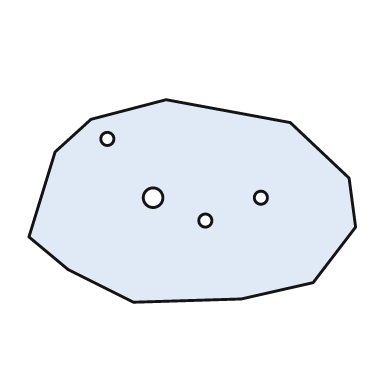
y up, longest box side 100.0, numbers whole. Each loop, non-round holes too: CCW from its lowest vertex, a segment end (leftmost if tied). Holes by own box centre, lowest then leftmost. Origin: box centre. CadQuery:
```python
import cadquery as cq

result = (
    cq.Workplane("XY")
    .moveTo(-18.0, -31.0)
    .lineTo(15.0, -30.0)
    .lineTo(37.0, -25.0)
    .lineTo(50.0, -8.0)
    .lineTo(48.0, 7.0)
    .lineTo(30.0, 24.0)
    .lineTo(-8.0, 31.0)
    .lineTo(-31.0, 25.0)
    .lineTo(-42.0, 15.0)
    .lineTo(-50.0, -11.0)
    .lineTo(-38.0, -21.0)
    .close()
    .moveTo(4.0, -6.0)
    .circle(2.0)
    .moveTo(-12.0, 1.0)
    .circle(3.0)
    .moveTo(21.0, 1.0)
    .circle(2.0)
    .moveTo(-26.0, 19.0)
    .circle(2.0)
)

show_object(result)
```